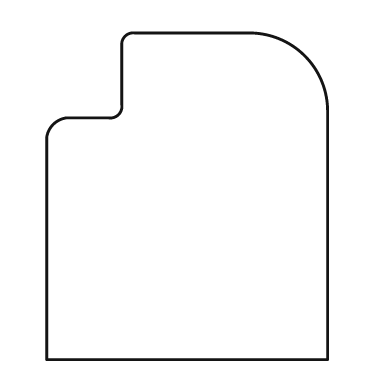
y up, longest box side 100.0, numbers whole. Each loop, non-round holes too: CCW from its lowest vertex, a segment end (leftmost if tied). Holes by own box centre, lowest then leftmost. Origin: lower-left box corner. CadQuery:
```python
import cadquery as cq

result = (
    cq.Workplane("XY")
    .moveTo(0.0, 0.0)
    .lineTo(86.0, 0.0)
    .lineTo(86.0, 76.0)
    .threePointArc((79.0, 93.0), (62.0, 100.0))
    .lineTo(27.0, 100.0)
    .threePointArc((24.0, 99.0), (23.0, 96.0))
    .lineTo(23.0, 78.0)
    .threePointArc((22.0, 75.0), (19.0, 74.0))
    .lineTo(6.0, 74.0)
    .threePointArc((2.0, 72.0), (0.0, 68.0))
    .close()
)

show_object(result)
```